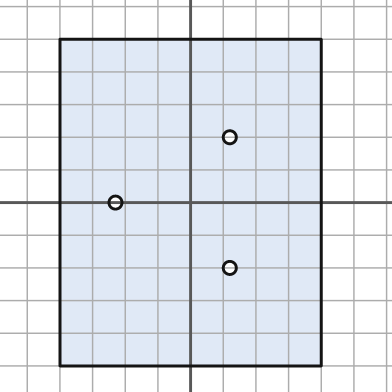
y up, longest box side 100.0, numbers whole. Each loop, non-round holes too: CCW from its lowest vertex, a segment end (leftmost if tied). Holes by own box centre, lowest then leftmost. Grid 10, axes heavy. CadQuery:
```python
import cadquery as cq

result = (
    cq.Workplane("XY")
    .moveTo(-40.0, -50.0)
    .lineTo(40.0, -50.0)
    .lineTo(40.0, 50.0)
    .lineTo(-40.0, 50.0)
    .close()
    .moveTo(12.0, -20.0)
    .circle(2.0)
    .moveTo(-23.0, 0.0)
    .circle(2.0)
    .moveTo(12.0, 20.0)
    .circle(2.0)
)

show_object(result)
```